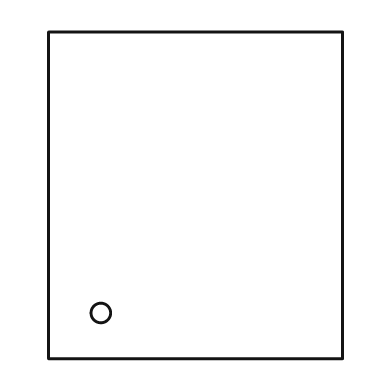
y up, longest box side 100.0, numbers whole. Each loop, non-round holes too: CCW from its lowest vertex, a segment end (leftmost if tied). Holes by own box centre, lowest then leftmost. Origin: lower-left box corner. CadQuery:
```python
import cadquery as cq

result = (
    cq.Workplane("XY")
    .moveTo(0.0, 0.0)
    .lineTo(90.0, 0.0)
    .lineTo(90.0, 100.0)
    .lineTo(0.0, 100.0)
    .close()
    .moveTo(16.0, 14.0)
    .circle(3.0)
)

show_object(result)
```